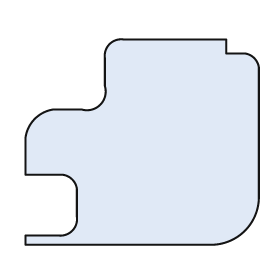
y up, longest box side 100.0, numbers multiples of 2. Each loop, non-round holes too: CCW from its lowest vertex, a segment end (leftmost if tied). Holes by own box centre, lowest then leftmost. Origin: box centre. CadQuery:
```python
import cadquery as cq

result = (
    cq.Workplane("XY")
    .moveTo(-50.0, -44.0)
    .lineTo(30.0, -44.0)
    .threePointArc((44.0, -38.0), (50.0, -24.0))
    .lineTo(50.0, 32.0)
    .threePointArc((48.0, 36.0), (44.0, 38.0))
    .lineTo(36.0, 38.0)
    .lineTo(36.0, 44.0)
    .lineTo(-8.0, 44.0)
    .threePointArc((-14.0, 42.0), (-16.0, 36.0))
    .lineTo(-16.0, 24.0)
    .threePointArc((-18.0, 16.0), (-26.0, 14.0))
    .lineTo(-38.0, 14.0)
    .threePointArc((-46.0, 10.0), (-50.0, 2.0))
    .lineTo(-50.0, -14.0)
    .lineTo(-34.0, -14.0)
    .threePointArc((-30.0, -16.0), (-28.0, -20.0))
    .lineTo(-28.0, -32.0)
    .threePointArc((-30.0, -38.0), (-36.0, -40.0))
    .lineTo(-50.0, -40.0)
    .close()
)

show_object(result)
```